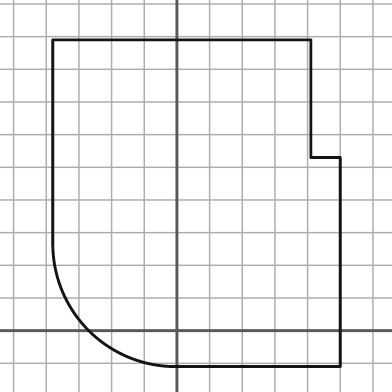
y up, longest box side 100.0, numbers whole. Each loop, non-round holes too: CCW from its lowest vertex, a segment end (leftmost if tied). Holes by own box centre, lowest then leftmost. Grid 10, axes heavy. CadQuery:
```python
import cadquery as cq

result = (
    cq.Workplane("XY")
    .moveTo(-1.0, -11.0)
    .lineTo(50.0, -11.0)
    .lineTo(50.0, 53.0)
    .lineTo(41.0, 53.0)
    .lineTo(41.0, 89.0)
    .lineTo(-38.0, 89.0)
    .lineTo(-38.0, 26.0)
    .threePointArc((-27.0, 0.0), (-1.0, -11.0))
    .close()
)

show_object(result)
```